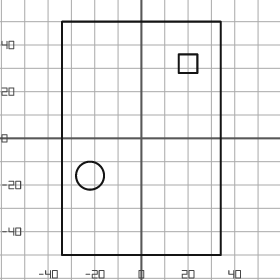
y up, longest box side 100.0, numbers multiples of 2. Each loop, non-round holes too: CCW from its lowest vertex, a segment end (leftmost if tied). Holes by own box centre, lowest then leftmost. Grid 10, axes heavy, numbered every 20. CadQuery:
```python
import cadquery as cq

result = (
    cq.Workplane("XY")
    .moveTo(-34.0, -50.0)
    .lineTo(34.0, -50.0)
    .lineTo(34.0, 50.0)
    .lineTo(-34.0, 50.0)
    .close()
    .moveTo(-22.0, -16.0)
    .circle(6.0)
    .moveTo(16.0, 28.0)
    .lineTo(24.0, 28.0)
    .lineTo(24.0, 36.0)
    .lineTo(16.0, 36.0)
    .close()
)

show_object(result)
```